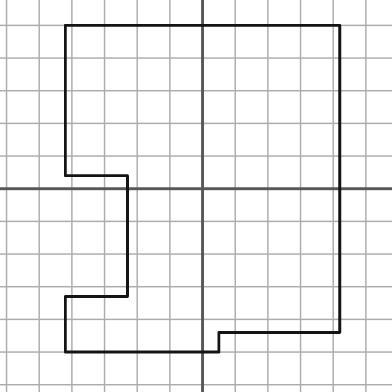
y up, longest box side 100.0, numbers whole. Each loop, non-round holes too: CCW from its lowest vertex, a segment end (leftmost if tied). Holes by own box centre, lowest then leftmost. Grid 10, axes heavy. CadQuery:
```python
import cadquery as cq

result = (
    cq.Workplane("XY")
    .moveTo(-42.0, -50.0)
    .lineTo(5.0, -50.0)
    .lineTo(5.0, -44.0)
    .lineTo(42.0, -44.0)
    .lineTo(42.0, 50.0)
    .lineTo(-42.0, 50.0)
    .lineTo(-42.0, 4.0)
    .lineTo(-23.0, 4.0)
    .lineTo(-23.0, -33.0)
    .lineTo(-42.0, -33.0)
    .close()
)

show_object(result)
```